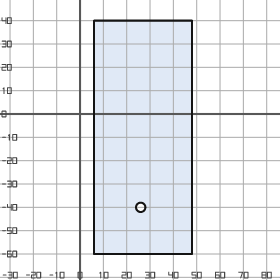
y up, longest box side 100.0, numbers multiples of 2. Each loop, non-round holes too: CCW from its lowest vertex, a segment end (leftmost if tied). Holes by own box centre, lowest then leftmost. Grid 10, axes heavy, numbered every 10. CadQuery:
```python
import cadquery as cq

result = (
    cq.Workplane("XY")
    .moveTo(6.0, -60.0)
    .lineTo(48.0, -60.0)
    .lineTo(48.0, 40.0)
    .lineTo(6.0, 40.0)
    .close()
    .moveTo(26.0, -40.0)
    .circle(2.0)
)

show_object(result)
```